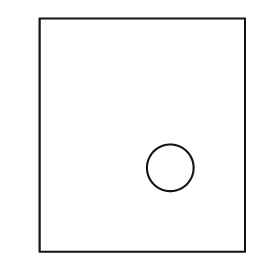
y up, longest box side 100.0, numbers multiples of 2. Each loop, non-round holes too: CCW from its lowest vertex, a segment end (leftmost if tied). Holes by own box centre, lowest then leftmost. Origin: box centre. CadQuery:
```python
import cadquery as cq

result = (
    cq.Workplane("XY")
    .moveTo(-44.0, -50.0)
    .lineTo(44.0, -50.0)
    .lineTo(44.0, 50.0)
    .lineTo(-44.0, 50.0)
    .close()
    .moveTo(12.0, -14.0)
    .circle(10.0)
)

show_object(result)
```